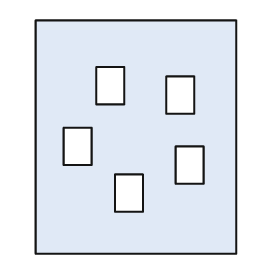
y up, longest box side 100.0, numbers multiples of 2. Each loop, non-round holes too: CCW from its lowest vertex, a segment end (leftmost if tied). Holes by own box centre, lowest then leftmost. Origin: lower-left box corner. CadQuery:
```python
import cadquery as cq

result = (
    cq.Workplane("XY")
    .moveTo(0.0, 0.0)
    .lineTo(86.0, 0.0)
    .lineTo(86.0, 100.0)
    .lineTo(0.0, 100.0)
    .close()
    .moveTo(34.0, 18.0)
    .lineTo(46.0, 18.0)
    .lineTo(46.0, 34.0)
    .lineTo(34.0, 34.0)
    .close()
    .moveTo(60.0, 30.0)
    .lineTo(72.0, 30.0)
    .lineTo(72.0, 46.0)
    .lineTo(60.0, 46.0)
    .close()
    .moveTo(12.0, 38.0)
    .lineTo(24.0, 38.0)
    .lineTo(24.0, 54.0)
    .lineTo(12.0, 54.0)
    .close()
    .moveTo(56.0, 60.0)
    .lineTo(68.0, 60.0)
    .lineTo(68.0, 76.0)
    .lineTo(56.0, 76.0)
    .close()
    .moveTo(26.0, 64.0)
    .lineTo(38.0, 64.0)
    .lineTo(38.0, 80.0)
    .lineTo(26.0, 80.0)
    .close()
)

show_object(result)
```